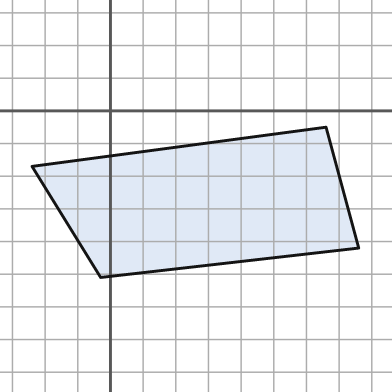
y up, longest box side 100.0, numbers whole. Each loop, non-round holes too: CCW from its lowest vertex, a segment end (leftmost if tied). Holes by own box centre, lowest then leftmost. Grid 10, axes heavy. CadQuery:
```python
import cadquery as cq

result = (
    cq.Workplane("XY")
    .moveTo(-3.0, -51.0)
    .lineTo(76.0, -42.0)
    .lineTo(66.0, -5.0)
    .lineTo(-24.0, -17.0)
    .close()
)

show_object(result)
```